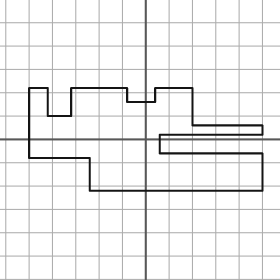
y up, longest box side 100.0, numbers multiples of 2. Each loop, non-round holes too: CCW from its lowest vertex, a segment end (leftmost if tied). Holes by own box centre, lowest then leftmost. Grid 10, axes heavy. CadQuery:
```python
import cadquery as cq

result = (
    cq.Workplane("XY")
    .moveTo(-24.0, -22.0)
    .lineTo(50.0, -22.0)
    .lineTo(50.0, -6.0)
    .lineTo(6.0, -6.0)
    .lineTo(6.0, 2.0)
    .lineTo(50.0, 2.0)
    .lineTo(50.0, 6.0)
    .lineTo(20.0, 6.0)
    .lineTo(20.0, 22.0)
    .lineTo(4.0, 22.0)
    .lineTo(4.0, 16.0)
    .lineTo(-8.0, 16.0)
    .lineTo(-8.0, 22.0)
    .lineTo(-32.0, 22.0)
    .lineTo(-32.0, 10.0)
    .lineTo(-42.0, 10.0)
    .lineTo(-42.0, 22.0)
    .lineTo(-50.0, 22.0)
    .lineTo(-50.0, -8.0)
    .lineTo(-24.0, -8.0)
    .close()
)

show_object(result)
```